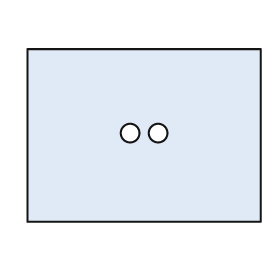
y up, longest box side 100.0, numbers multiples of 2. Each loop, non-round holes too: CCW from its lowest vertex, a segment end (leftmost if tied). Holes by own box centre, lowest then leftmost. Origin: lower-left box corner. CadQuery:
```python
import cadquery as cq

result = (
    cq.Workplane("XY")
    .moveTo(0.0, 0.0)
    .lineTo(100.0, 0.0)
    .lineTo(100.0, 74.0)
    .lineTo(0.0, 74.0)
    .close()
    .moveTo(44.0, 38.0)
    .circle(4.0)
    .moveTo(56.0, 38.0)
    .circle(4.0)
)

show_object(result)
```